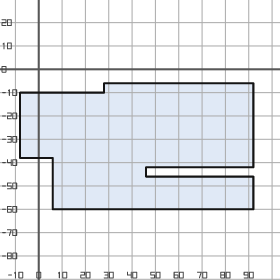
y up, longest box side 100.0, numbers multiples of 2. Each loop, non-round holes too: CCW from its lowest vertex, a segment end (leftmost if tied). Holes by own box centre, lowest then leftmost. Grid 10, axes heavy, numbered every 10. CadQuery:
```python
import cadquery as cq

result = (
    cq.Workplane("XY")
    .moveTo(6.0, -60.0)
    .lineTo(92.0, -60.0)
    .lineTo(92.0, -46.0)
    .lineTo(46.0, -46.0)
    .lineTo(46.0, -42.0)
    .lineTo(92.0, -42.0)
    .lineTo(92.0, -6.0)
    .lineTo(28.0, -6.0)
    .lineTo(28.0, -10.0)
    .lineTo(-8.0, -10.0)
    .lineTo(-8.0, -38.0)
    .lineTo(6.0, -38.0)
    .close()
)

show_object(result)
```